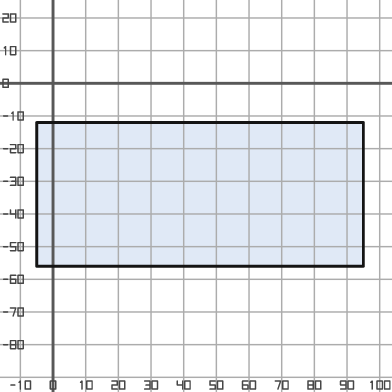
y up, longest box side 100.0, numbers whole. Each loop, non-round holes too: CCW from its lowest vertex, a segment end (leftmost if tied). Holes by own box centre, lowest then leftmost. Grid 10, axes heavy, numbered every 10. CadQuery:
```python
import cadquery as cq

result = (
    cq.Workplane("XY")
    .moveTo(-5.0, -56.0)
    .lineTo(95.0, -56.0)
    .lineTo(95.0, -12.0)
    .lineTo(-5.0, -12.0)
    .close()
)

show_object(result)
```